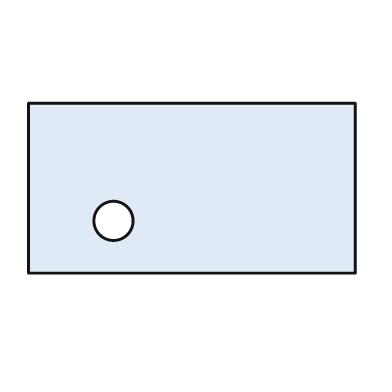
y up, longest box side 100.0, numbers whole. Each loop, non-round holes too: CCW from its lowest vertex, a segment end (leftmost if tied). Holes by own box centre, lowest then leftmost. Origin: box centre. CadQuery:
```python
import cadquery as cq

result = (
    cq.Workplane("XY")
    .moveTo(-50.0, -26.0)
    .lineTo(50.0, -26.0)
    .lineTo(50.0, 26.0)
    .lineTo(-50.0, 26.0)
    .close()
    .moveTo(-24.0, -10.0)
    .circle(6.0)
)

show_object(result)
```